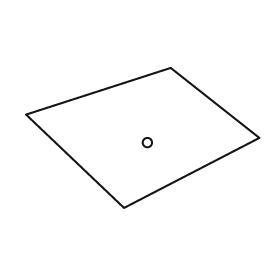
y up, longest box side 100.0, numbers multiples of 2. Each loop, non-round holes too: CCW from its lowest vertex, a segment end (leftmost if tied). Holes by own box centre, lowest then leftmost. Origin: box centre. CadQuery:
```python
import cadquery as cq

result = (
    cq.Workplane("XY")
    .moveTo(-8.0, -30.0)
    .lineTo(50.0, 0.0)
    .lineTo(12.0, 30.0)
    .lineTo(-50.0, 10.0)
    .close()
    .moveTo(2.0, -2.0)
    .circle(2.0)
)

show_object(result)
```